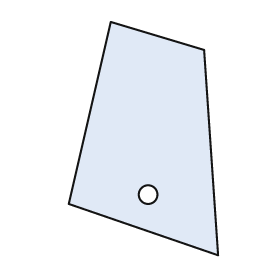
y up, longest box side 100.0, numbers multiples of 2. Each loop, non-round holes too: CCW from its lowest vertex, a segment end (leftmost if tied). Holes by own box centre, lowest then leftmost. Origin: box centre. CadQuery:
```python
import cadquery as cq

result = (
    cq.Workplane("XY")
    .moveTo(32.0, -50.0)
    .lineTo(26.0, 38.0)
    .lineTo(-14.0, 50.0)
    .lineTo(-32.0, -28.0)
    .close()
    .moveTo(2.0, -24.0)
    .circle(4.0)
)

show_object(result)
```